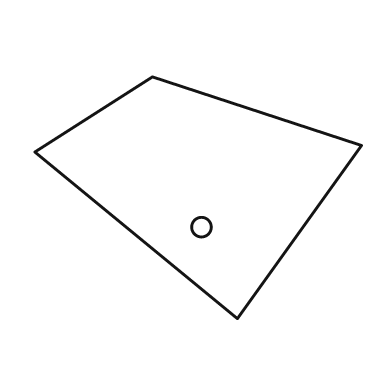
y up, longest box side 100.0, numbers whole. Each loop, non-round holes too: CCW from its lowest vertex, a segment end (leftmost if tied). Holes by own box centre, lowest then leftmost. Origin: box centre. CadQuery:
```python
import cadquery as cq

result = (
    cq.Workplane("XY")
    .moveTo(12.0, -37.0)
    .lineTo(50.0, 16.0)
    .lineTo(-14.0, 37.0)
    .lineTo(-50.0, 14.0)
    .close()
    .moveTo(1.0, -9.0)
    .circle(3.0)
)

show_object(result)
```